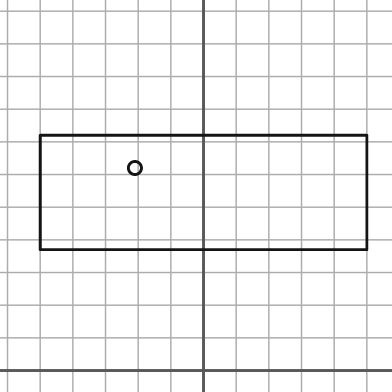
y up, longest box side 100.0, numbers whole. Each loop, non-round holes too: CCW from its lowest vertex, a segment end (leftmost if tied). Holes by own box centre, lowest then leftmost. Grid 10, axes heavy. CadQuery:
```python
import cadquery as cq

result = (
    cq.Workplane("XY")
    .moveTo(-50.0, 37.0)
    .lineTo(50.0, 37.0)
    .lineTo(50.0, 72.0)
    .lineTo(-50.0, 72.0)
    .close()
    .moveTo(-21.0, 62.0)
    .circle(2.0)
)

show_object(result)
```